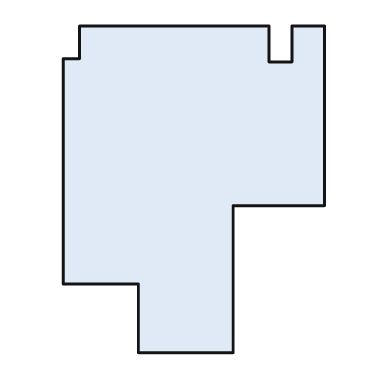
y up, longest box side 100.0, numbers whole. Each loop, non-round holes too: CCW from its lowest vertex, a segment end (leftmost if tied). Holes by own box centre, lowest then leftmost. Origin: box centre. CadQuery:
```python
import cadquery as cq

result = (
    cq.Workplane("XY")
    .moveTo(-17.0, -50.0)
    .lineTo(12.0, -50.0)
    .lineTo(12.0, -5.0)
    .lineTo(40.0, -5.0)
    .lineTo(40.0, 50.0)
    .lineTo(30.0, 50.0)
    .lineTo(30.0, 39.0)
    .lineTo(23.0, 39.0)
    .lineTo(23.0, 50.0)
    .lineTo(-35.0, 50.0)
    .lineTo(-35.0, 40.0)
    .lineTo(-40.0, 40.0)
    .lineTo(-40.0, -29.0)
    .lineTo(-17.0, -29.0)
    .close()
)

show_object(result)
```